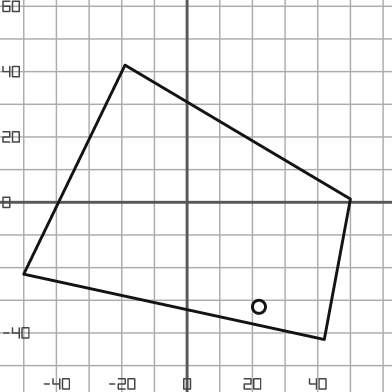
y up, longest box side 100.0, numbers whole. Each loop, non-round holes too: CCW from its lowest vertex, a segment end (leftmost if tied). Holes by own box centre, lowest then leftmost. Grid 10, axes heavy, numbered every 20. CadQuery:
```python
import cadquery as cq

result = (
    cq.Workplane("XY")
    .moveTo(42.0, -42.0)
    .lineTo(50.0, 1.0)
    .lineTo(-19.0, 42.0)
    .lineTo(-50.0, -22.0)
    .close()
    .moveTo(22.0, -32.0)
    .circle(2.0)
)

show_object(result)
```